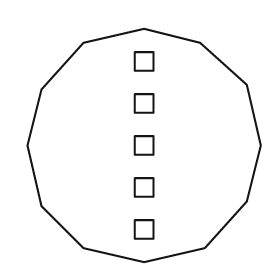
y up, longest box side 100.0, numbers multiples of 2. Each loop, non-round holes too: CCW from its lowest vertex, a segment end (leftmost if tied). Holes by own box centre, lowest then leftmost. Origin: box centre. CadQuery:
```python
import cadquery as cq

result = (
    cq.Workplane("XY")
    .moveTo(0.0, -50.0)
    .lineTo(26.0, -44.0)
    .lineTo(44.0, -24.0)
    .lineTo(50.0, 0.0)
    .lineTo(44.0, 26.0)
    .lineTo(24.0, 44.0)
    .lineTo(0.0, 50.0)
    .lineTo(-26.0, 44.0)
    .lineTo(-44.0, 24.0)
    .lineTo(-50.0, 0.0)
    .lineTo(-44.0, -26.0)
    .lineTo(-26.0, -44.0)
    .close()
    .moveTo(-4.0, -40.0)
    .lineTo(4.0, -40.0)
    .lineTo(4.0, -32.0)
    .lineTo(-4.0, -32.0)
    .close()
    .moveTo(-4.0, -22.0)
    .lineTo(4.0, -22.0)
    .lineTo(4.0, -14.0)
    .lineTo(-4.0, -14.0)
    .close()
    .moveTo(-4.0, -4.0)
    .lineTo(4.0, -4.0)
    .lineTo(4.0, 4.0)
    .lineTo(-4.0, 4.0)
    .close()
    .moveTo(-4.0, 14.0)
    .lineTo(4.0, 14.0)
    .lineTo(4.0, 22.0)
    .lineTo(-4.0, 22.0)
    .close()
    .moveTo(-4.0, 32.0)
    .lineTo(4.0, 32.0)
    .lineTo(4.0, 40.0)
    .lineTo(-4.0, 40.0)
    .close()
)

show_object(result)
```